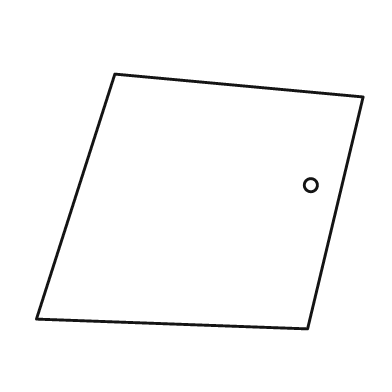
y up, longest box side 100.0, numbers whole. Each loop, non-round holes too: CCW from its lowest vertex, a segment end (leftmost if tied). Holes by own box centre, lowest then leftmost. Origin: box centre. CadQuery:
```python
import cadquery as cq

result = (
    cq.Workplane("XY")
    .moveTo(33.0, -39.0)
    .lineTo(50.0, 32.0)
    .lineTo(-26.0, 39.0)
    .lineTo(-50.0, -36.0)
    .close()
    .moveTo(34.0, 5.0)
    .circle(2.0)
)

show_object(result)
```